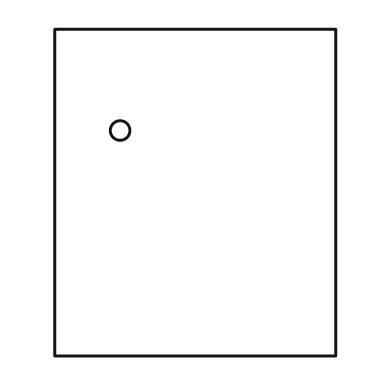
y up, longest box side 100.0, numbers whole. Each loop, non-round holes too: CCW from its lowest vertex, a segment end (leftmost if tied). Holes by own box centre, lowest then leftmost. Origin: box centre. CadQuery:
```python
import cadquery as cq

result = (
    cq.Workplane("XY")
    .moveTo(-43.0, -50.0)
    .lineTo(43.0, -50.0)
    .lineTo(43.0, 50.0)
    .lineTo(-43.0, 50.0)
    .close()
    .moveTo(-23.0, 19.0)
    .circle(3.0)
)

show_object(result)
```